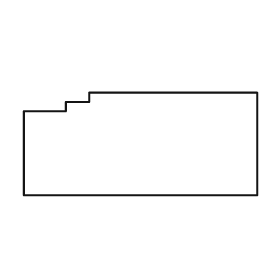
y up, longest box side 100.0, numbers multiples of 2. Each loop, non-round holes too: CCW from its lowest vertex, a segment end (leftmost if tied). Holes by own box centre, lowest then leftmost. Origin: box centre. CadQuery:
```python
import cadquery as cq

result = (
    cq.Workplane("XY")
    .moveTo(-50.0, -22.0)
    .lineTo(50.0, -22.0)
    .lineTo(50.0, 22.0)
    .lineTo(-22.0, 22.0)
    .lineTo(-22.0, 18.0)
    .lineTo(-32.0, 18.0)
    .lineTo(-32.0, 14.0)
    .lineTo(-50.0, 14.0)
    .close()
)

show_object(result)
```